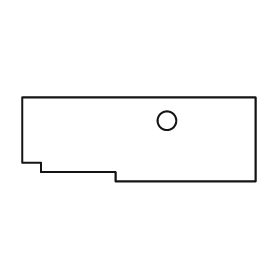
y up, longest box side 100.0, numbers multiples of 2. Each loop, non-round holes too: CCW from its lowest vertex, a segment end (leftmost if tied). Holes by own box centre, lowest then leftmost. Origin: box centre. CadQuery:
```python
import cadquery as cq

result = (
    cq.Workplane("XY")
    .moveTo(-10.0, -18.0)
    .lineTo(50.0, -18.0)
    .lineTo(50.0, 18.0)
    .lineTo(-50.0, 18.0)
    .lineTo(-50.0, -10.0)
    .lineTo(-42.0, -10.0)
    .lineTo(-42.0, -14.0)
    .lineTo(-10.0, -14.0)
    .close()
    .moveTo(12.0, 8.0)
    .circle(4.0)
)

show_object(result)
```